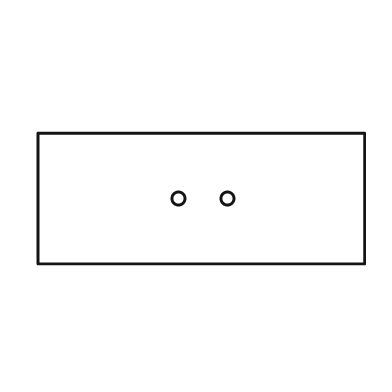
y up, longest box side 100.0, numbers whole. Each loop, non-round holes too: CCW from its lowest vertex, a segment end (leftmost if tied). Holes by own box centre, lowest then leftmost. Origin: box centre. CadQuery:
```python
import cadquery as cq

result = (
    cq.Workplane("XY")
    .moveTo(-50.0, -20.0)
    .lineTo(50.0, -20.0)
    .lineTo(50.0, 20.0)
    .lineTo(-50.0, 20.0)
    .close()
    .moveTo(-7.0, 0.0)
    .circle(2.0)
    .moveTo(8.0, 0.0)
    .circle(2.0)
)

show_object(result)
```